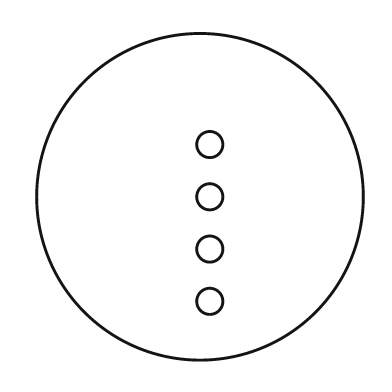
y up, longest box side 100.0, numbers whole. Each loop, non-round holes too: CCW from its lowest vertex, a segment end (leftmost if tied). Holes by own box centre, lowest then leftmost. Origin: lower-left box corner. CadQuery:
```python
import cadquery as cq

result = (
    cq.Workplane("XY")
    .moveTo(50.0, 50.0)
    .circle(50.0)
    .moveTo(53.0, 18.0)
    .circle(4.0)
    .moveTo(53.0, 34.0)
    .circle(4.0)
    .moveTo(53.0, 50.0)
    .circle(4.0)
    .moveTo(53.0, 66.0)
    .circle(4.0)
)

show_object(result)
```